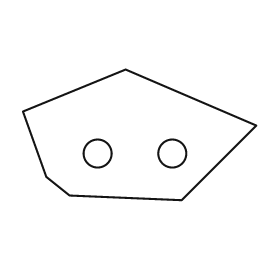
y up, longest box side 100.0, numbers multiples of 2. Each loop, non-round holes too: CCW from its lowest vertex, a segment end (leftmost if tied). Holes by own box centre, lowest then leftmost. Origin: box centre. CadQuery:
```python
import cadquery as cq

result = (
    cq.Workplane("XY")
    .moveTo(18.0, -28.0)
    .lineTo(50.0, 4.0)
    .lineTo(-6.0, 28.0)
    .lineTo(-50.0, 10.0)
    .lineTo(-40.0, -18.0)
    .lineTo(-30.0, -26.0)
    .close()
    .moveTo(-18.0, -8.0)
    .circle(6.0)
    .moveTo(14.0, -8.0)
    .circle(6.0)
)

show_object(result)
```